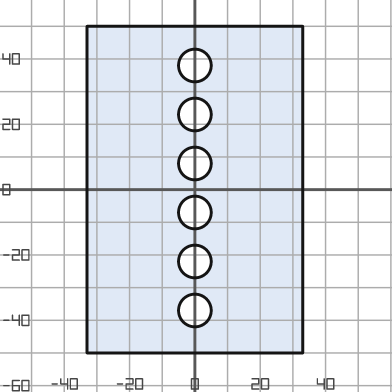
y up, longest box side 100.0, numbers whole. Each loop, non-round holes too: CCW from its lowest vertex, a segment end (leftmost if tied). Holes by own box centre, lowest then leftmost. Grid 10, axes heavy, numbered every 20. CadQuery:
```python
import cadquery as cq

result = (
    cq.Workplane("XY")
    .moveTo(-33.0, -50.0)
    .lineTo(33.0, -50.0)
    .lineTo(33.0, 50.0)
    .lineTo(-33.0, 50.0)
    .close()
    .moveTo(0.0, -37.0)
    .circle(5.0)
    .moveTo(0.0, -22.0)
    .circle(5.0)
    .moveTo(0.0, -7.0)
    .circle(5.0)
    .moveTo(0.0, 8.0)
    .circle(5.0)
    .moveTo(0.0, 23.0)
    .circle(5.0)
    .moveTo(0.0, 38.0)
    .circle(5.0)
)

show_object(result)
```